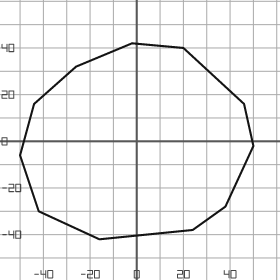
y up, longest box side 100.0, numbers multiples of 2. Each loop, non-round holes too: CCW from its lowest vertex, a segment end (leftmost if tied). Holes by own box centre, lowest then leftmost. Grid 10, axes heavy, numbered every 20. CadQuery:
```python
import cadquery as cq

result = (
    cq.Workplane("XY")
    .moveTo(-16.0, -42.0)
    .lineTo(24.0, -38.0)
    .lineTo(38.0, -28.0)
    .lineTo(50.0, -2.0)
    .lineTo(46.0, 16.0)
    .lineTo(20.0, 40.0)
    .lineTo(-2.0, 42.0)
    .lineTo(-26.0, 32.0)
    .lineTo(-44.0, 16.0)
    .lineTo(-50.0, -6.0)
    .lineTo(-42.0, -30.0)
    .close()
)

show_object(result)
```